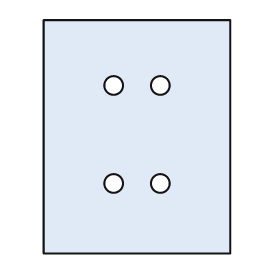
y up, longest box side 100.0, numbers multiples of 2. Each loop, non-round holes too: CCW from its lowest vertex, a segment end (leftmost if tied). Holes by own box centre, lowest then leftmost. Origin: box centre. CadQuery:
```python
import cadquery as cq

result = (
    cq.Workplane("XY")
    .moveTo(-40.0, -50.0)
    .lineTo(40.0, -50.0)
    .lineTo(40.0, 50.0)
    .lineTo(-40.0, 50.0)
    .close()
    .moveTo(-10.0, -20.0)
    .circle(4.0)
    .moveTo(10.0, -20.0)
    .circle(4.0)
    .moveTo(-10.0, 22.0)
    .circle(4.0)
    .moveTo(10.0, 22.0)
    .circle(4.0)
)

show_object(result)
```